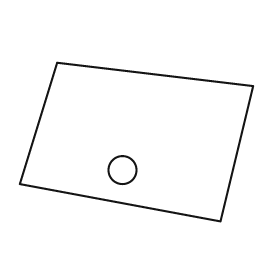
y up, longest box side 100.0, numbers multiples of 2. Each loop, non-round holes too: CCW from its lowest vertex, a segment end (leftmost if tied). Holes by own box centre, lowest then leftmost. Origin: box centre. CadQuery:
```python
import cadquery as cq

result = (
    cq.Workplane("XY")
    .moveTo(36.0, -34.0)
    .lineTo(50.0, 24.0)
    .lineTo(-34.0, 34.0)
    .lineTo(-50.0, -18.0)
    .close()
    .moveTo(-6.0, -12.0)
    .circle(6.0)
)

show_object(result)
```